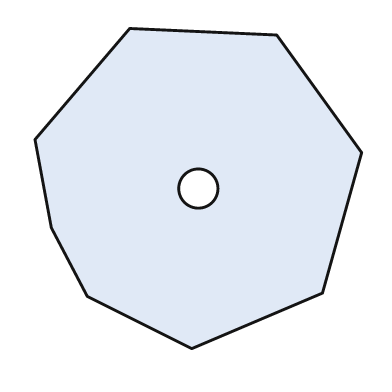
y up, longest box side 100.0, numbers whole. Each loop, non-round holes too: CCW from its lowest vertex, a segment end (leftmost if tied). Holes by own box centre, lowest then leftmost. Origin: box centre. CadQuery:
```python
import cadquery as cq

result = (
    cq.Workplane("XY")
    .moveTo(-2.0, -49.0)
    .lineTo(38.0, -32.0)
    .lineTo(50.0, 11.0)
    .lineTo(24.0, 47.0)
    .lineTo(-21.0, 49.0)
    .lineTo(-50.0, 15.0)
    .lineTo(-45.0, -12.0)
    .lineTo(-34.0, -33.0)
    .close()
    .moveTo(0.0, 0.0)
    .circle(6.0)
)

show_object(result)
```